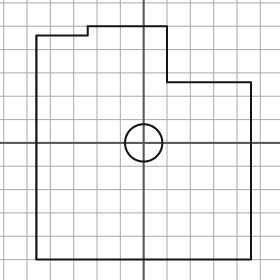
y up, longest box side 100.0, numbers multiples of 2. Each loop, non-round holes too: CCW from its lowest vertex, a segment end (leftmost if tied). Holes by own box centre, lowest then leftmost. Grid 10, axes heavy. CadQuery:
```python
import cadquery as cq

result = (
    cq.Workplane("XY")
    .moveTo(-46.0, -50.0)
    .lineTo(46.0, -50.0)
    .lineTo(46.0, 26.0)
    .lineTo(10.0, 26.0)
    .lineTo(10.0, 50.0)
    .lineTo(-24.0, 50.0)
    .lineTo(-24.0, 46.0)
    .lineTo(-46.0, 46.0)
    .close()
    .moveTo(0.0, 0.0)
    .circle(8.0)
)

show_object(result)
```